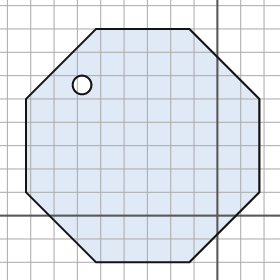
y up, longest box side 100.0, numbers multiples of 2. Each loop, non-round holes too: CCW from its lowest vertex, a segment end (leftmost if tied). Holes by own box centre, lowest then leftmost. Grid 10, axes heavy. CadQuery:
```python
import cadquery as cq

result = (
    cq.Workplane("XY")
    .moveTo(-52.0, -20.0)
    .lineTo(-12.0, -20.0)
    .lineTo(18.0, 10.0)
    .lineTo(18.0, 50.0)
    .lineTo(-12.0, 80.0)
    .lineTo(-52.0, 80.0)
    .lineTo(-82.0, 50.0)
    .lineTo(-82.0, 10.0)
    .close()
    .moveTo(-58.0, 56.0)
    .circle(4.0)
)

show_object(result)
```